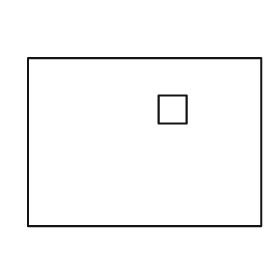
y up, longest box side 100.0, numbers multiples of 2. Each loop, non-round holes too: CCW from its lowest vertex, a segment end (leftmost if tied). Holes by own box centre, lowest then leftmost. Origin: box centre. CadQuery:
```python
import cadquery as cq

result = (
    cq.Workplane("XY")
    .moveTo(-50.0, -36.0)
    .lineTo(50.0, -36.0)
    .lineTo(50.0, 36.0)
    .lineTo(-50.0, 36.0)
    .close()
    .moveTo(6.0, 8.0)
    .lineTo(18.0, 8.0)
    .lineTo(18.0, 20.0)
    .lineTo(6.0, 20.0)
    .close()
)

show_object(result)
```